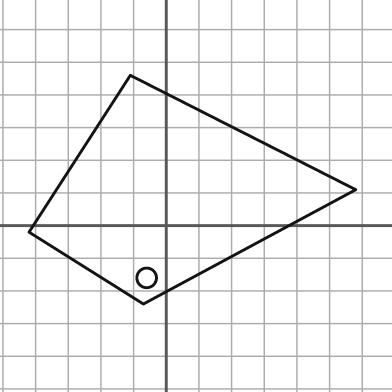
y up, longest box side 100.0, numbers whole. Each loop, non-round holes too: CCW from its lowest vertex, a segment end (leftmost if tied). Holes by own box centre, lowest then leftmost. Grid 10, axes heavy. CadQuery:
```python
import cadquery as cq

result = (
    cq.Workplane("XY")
    .moveTo(-7.0, -24.0)
    .lineTo(58.0, 11.0)
    .lineTo(-11.0, 46.0)
    .lineTo(-42.0, -2.0)
    .close()
    .moveTo(-6.0, -16.0)
    .circle(3.0)
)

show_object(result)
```